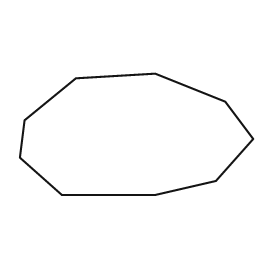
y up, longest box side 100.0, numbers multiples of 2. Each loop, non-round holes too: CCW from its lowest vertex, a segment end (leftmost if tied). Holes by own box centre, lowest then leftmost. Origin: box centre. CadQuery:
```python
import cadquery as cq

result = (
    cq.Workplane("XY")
    .moveTo(-32.0, -26.0)
    .lineTo(8.0, -26.0)
    .lineTo(34.0, -20.0)
    .lineTo(50.0, -2.0)
    .lineTo(38.0, 14.0)
    .lineTo(8.0, 26.0)
    .lineTo(-26.0, 24.0)
    .lineTo(-48.0, 6.0)
    .lineTo(-50.0, -10.0)
    .close()
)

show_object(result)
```